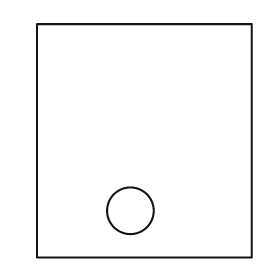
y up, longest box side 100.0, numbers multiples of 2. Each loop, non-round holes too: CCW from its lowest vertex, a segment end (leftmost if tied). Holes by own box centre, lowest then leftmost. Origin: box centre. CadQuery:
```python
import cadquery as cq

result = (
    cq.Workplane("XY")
    .moveTo(-46.0, -50.0)
    .lineTo(46.0, -50.0)
    .lineTo(46.0, 50.0)
    .lineTo(-46.0, 50.0)
    .close()
    .moveTo(-6.0, -30.0)
    .circle(10.0)
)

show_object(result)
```